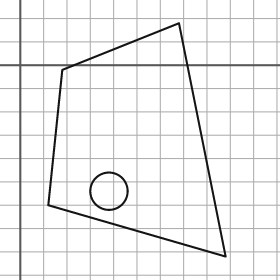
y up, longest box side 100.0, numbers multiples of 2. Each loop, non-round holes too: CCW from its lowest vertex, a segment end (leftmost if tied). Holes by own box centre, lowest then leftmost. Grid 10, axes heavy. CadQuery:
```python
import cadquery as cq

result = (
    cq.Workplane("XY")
    .moveTo(88.0, -82.0)
    .lineTo(68.0, 18.0)
    .lineTo(18.0, -2.0)
    .lineTo(12.0, -60.0)
    .close()
    .moveTo(38.0, -54.0)
    .circle(8.0)
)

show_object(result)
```